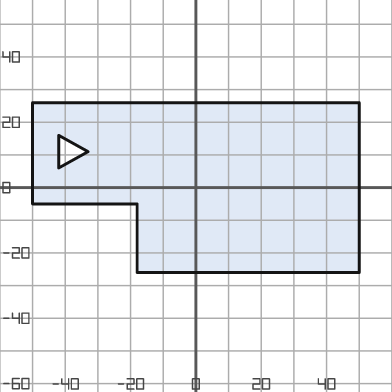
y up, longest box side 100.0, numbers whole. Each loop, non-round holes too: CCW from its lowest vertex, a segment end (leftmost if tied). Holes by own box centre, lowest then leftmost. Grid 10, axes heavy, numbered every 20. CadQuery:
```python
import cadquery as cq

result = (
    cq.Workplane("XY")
    .moveTo(-18.0, -26.0)
    .lineTo(50.0, -26.0)
    .lineTo(50.0, 26.0)
    .lineTo(-50.0, 26.0)
    .lineTo(-50.0, -5.0)
    .lineTo(-18.0, -5.0)
    .close()
    .moveTo(-42.0, 6.0)
    .lineTo(-33.0, 11.0)
    .lineTo(-42.0, 16.0)
    .close()
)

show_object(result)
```